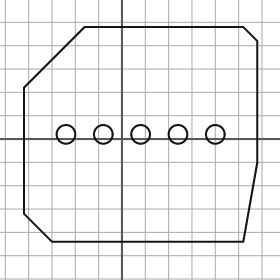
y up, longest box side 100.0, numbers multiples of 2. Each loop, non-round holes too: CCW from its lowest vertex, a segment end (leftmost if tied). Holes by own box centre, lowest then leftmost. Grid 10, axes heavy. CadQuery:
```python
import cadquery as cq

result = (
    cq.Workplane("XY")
    .moveTo(-30.0, -44.0)
    .lineTo(52.0, -44.0)
    .lineTo(58.0, -10.0)
    .lineTo(58.0, 42.0)
    .lineTo(52.0, 48.0)
    .lineTo(-16.0, 48.0)
    .lineTo(-42.0, 22.0)
    .lineTo(-42.0, -32.0)
    .close()
    .moveTo(-24.0, 2.0)
    .circle(4.0)
    .moveTo(-8.0, 2.0)
    .circle(4.0)
    .moveTo(8.0, 2.0)
    .circle(4.0)
    .moveTo(24.0, 2.0)
    .circle(4.0)
    .moveTo(40.0, 2.0)
    .circle(4.0)
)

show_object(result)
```